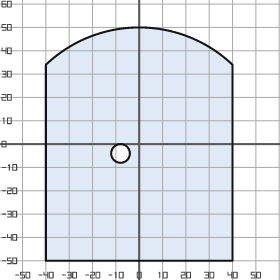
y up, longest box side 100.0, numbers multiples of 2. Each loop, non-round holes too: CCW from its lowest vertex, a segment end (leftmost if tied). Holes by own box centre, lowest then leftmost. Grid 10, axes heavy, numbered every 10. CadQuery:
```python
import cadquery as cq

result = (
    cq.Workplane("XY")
    .moveTo(-40.0, -50.0)
    .lineTo(40.0, -50.0)
    .lineTo(40.0, 34.0)
    .threePointArc((0.0, 50.0), (-40.0, 34.0))
    .close()
    .moveTo(-8.0, -4.0)
    .circle(4.0)
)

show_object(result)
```